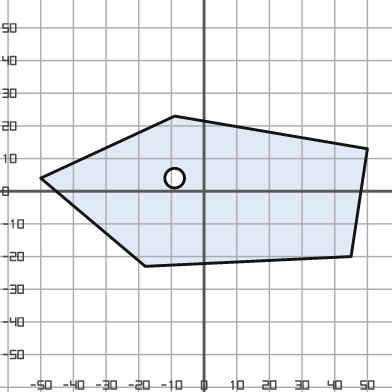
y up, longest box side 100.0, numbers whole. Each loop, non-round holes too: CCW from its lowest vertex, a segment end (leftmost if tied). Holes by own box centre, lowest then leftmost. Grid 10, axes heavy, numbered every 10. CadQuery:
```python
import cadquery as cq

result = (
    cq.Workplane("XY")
    .moveTo(-18.0, -23.0)
    .lineTo(45.0, -20.0)
    .lineTo(50.0, 13.0)
    .lineTo(-9.0, 23.0)
    .lineTo(-50.0, 4.0)
    .close()
    .moveTo(-9.0, 4.0)
    .circle(3.0)
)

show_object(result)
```